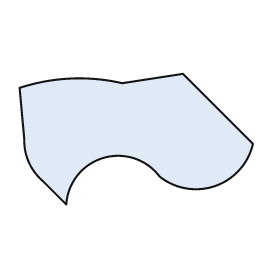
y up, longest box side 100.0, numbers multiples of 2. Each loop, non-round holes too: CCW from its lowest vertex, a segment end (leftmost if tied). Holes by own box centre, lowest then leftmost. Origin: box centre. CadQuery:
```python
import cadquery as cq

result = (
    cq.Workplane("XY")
    .moveTo(-30.0, -28.0)
    .threePointArc((-14.0, -8.0), (10.0, -16.0))
    .threePointArc((34.0, -20.0), (50.0, -2.0))
    .lineTo(20.0, 28.0)
    .lineTo(-6.0, 24.0)
    .threePointArc((-28.0, 26.0), (-50.0, 22.0))
    .lineTo(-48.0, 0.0)
    .threePointArc((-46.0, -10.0), (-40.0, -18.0))
    .close()
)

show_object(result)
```